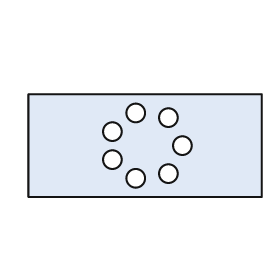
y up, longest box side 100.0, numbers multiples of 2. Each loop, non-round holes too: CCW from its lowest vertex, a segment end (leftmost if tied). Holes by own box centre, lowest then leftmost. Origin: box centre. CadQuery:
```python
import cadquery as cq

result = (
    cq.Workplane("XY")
    .moveTo(-50.0, -22.0)
    .lineTo(50.0, -22.0)
    .lineTo(50.0, 22.0)
    .lineTo(-50.0, 22.0)
    .close()
    .moveTo(-4.0, -14.0)
    .circle(4.0)
    .moveTo(10.0, -12.0)
    .circle(4.0)
    .moveTo(-14.0, -6.0)
    .circle(4.0)
    .moveTo(16.0, 0.0)
    .circle(4.0)
    .moveTo(-14.0, 6.0)
    .circle(4.0)
    .moveTo(10.0, 12.0)
    .circle(4.0)
    .moveTo(-4.0, 14.0)
    .circle(4.0)
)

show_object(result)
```